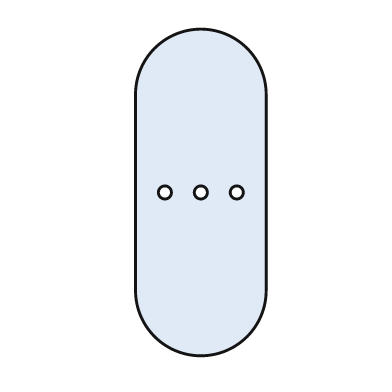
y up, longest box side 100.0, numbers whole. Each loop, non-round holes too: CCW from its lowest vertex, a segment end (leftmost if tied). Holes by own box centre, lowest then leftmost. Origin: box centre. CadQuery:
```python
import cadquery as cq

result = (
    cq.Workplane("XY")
    .moveTo(-20.0, -30.0)
    .threePointArc((0.0, -50.0), (20.0, -30.0))
    .lineTo(20.0, 30.0)
    .threePointArc((0.0, 50.0), (-20.0, 30.0))
    .close()
    .moveTo(-11.0, 0.0)
    .circle(2.0)
    .moveTo(0.0, 0.0)
    .circle(2.0)
    .moveTo(11.0, 0.0)
    .circle(2.0)
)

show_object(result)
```